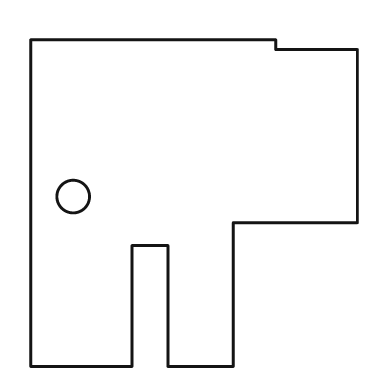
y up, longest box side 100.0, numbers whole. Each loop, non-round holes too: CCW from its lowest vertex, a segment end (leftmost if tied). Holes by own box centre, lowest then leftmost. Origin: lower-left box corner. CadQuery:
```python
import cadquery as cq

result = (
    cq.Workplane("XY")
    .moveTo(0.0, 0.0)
    .lineTo(31.0, 0.0)
    .lineTo(31.0, 37.0)
    .lineTo(42.0, 37.0)
    .lineTo(42.0, 0.0)
    .lineTo(62.0, 0.0)
    .lineTo(62.0, 44.0)
    .lineTo(100.0, 44.0)
    .lineTo(100.0, 97.0)
    .lineTo(75.0, 97.0)
    .lineTo(75.0, 100.0)
    .lineTo(0.0, 100.0)
    .close()
    .moveTo(13.0, 52.0)
    .circle(5.0)
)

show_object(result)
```